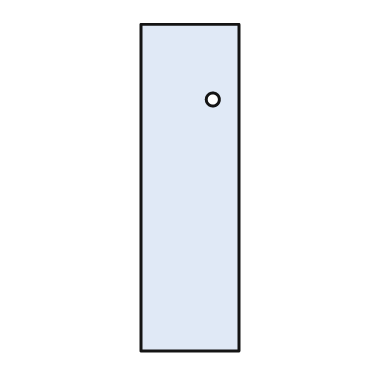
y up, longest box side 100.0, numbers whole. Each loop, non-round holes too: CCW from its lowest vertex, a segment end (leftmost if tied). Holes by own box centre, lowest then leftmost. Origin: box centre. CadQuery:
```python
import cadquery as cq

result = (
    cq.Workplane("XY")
    .moveTo(-15.0, -50.0)
    .lineTo(15.0, -50.0)
    .lineTo(15.0, 50.0)
    .lineTo(-15.0, 50.0)
    .close()
    .moveTo(7.0, 27.0)
    .circle(2.0)
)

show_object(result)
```